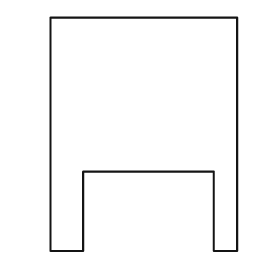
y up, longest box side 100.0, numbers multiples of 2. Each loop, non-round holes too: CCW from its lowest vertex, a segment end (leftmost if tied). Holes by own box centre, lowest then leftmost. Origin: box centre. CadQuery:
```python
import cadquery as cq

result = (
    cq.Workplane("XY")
    .moveTo(-40.0, -50.0)
    .lineTo(-26.0, -50.0)
    .lineTo(-26.0, -16.0)
    .lineTo(30.0, -16.0)
    .lineTo(30.0, -50.0)
    .lineTo(40.0, -50.0)
    .lineTo(40.0, 50.0)
    .lineTo(-40.0, 50.0)
    .close()
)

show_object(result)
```